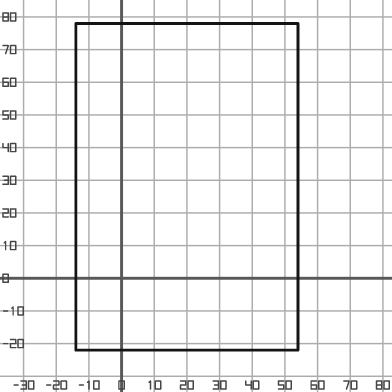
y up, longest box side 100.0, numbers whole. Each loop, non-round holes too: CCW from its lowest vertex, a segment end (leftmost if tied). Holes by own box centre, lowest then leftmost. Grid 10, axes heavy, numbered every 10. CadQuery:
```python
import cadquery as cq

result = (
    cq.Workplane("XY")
    .moveTo(-14.0, -22.0)
    .lineTo(54.0, -22.0)
    .lineTo(54.0, 78.0)
    .lineTo(-14.0, 78.0)
    .close()
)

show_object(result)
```